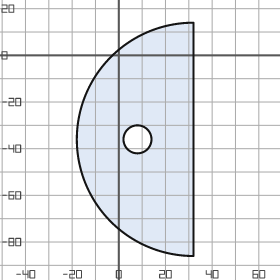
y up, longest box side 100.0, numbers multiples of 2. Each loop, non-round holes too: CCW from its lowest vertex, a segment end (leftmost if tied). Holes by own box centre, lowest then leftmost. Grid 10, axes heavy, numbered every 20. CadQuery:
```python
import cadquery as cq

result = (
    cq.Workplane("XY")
    .moveTo(32.0, -86.0)
    .lineTo(32.0, 14.0)
    .threePointArc((-18.0, -36.0), (32.0, -86.0))
    .close()
    .moveTo(8.0, -36.0)
    .circle(6.0)
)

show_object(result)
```